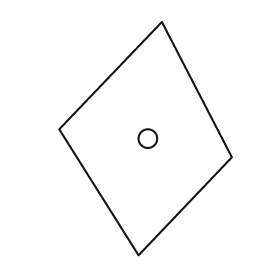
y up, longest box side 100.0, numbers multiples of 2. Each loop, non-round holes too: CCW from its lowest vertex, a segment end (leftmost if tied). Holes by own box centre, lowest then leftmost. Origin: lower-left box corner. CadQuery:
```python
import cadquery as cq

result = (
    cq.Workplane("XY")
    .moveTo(34.0, 0.0)
    .lineTo(74.0, 42.0)
    .lineTo(44.0, 100.0)
    .lineTo(0.0, 54.0)
    .close()
    .moveTo(38.0, 50.0)
    .circle(4.0)
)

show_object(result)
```